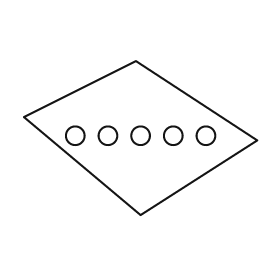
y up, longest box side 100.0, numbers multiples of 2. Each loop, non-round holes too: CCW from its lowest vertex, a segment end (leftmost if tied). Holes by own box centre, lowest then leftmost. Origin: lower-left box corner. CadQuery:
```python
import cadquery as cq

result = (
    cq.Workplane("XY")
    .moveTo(50.0, 0.0)
    .lineTo(100.0, 32.0)
    .lineTo(48.0, 66.0)
    .lineTo(0.0, 42.0)
    .close()
    .moveTo(22.0, 34.0)
    .circle(4.0)
    .moveTo(36.0, 34.0)
    .circle(4.0)
    .moveTo(50.0, 34.0)
    .circle(4.0)
    .moveTo(64.0, 34.0)
    .circle(4.0)
    .moveTo(78.0, 34.0)
    .circle(4.0)
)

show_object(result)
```